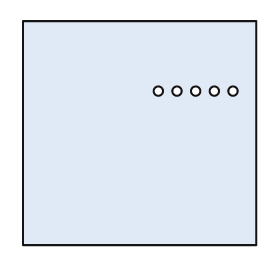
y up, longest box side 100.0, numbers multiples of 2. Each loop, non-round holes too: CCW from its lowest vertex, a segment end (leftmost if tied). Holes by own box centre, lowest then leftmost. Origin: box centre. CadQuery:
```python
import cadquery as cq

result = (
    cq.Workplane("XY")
    .moveTo(-50.0, -48.0)
    .lineTo(50.0, -48.0)
    .lineTo(50.0, 48.0)
    .lineTo(-50.0, 48.0)
    .close()
    .moveTo(8.0, 18.0)
    .circle(2.0)
    .moveTo(16.0, 18.0)
    .circle(2.0)
    .moveTo(24.0, 18.0)
    .circle(2.0)
    .moveTo(32.0, 18.0)
    .circle(2.0)
    .moveTo(40.0, 18.0)
    .circle(2.0)
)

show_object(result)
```